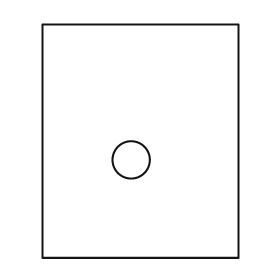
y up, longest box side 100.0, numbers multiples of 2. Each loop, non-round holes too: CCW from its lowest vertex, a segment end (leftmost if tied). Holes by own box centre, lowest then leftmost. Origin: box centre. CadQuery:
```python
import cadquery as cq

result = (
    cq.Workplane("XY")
    .moveTo(-42.0, -50.0)
    .lineTo(42.0, -50.0)
    .lineTo(42.0, 50.0)
    .lineTo(-42.0, 50.0)
    .close()
    .moveTo(-4.0, -8.0)
    .circle(8.0)
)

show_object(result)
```